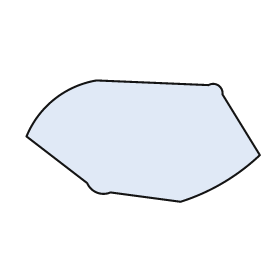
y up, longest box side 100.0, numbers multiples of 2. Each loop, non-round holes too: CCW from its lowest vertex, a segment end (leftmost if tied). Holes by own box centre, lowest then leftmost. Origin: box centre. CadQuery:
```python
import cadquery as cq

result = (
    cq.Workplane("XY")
    .moveTo(16.0, -26.0)
    .threePointArc((34.0, -18.0), (50.0, -6.0))
    .lineTo(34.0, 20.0)
    .threePointArc((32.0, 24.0), (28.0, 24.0))
    .lineTo(-20.0, 26.0)
    .threePointArc((-38.0, 18.0), (-50.0, 2.0))
    .lineTo(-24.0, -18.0)
    .threePointArc((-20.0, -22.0), (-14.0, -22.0))
    .close()
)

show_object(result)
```